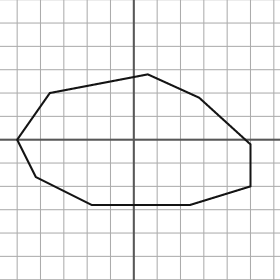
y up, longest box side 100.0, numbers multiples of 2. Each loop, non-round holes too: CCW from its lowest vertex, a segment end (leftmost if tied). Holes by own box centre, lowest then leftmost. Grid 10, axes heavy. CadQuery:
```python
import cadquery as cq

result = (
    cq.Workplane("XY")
    .moveTo(-18.0, -28.0)
    .lineTo(24.0, -28.0)
    .lineTo(50.0, -20.0)
    .lineTo(50.0, -2.0)
    .lineTo(28.0, 18.0)
    .lineTo(6.0, 28.0)
    .lineTo(-36.0, 20.0)
    .lineTo(-50.0, 0.0)
    .lineTo(-42.0, -16.0)
    .close()
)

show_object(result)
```